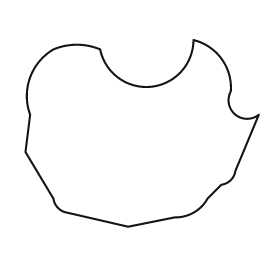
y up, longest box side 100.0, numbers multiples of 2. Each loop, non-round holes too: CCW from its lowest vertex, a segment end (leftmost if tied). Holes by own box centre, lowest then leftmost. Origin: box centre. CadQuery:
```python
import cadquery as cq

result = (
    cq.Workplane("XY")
    .moveTo(-6.0, -40.0)
    .lineTo(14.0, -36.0)
    .threePointArc((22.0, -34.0), (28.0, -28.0))
    .lineTo(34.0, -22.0)
    .threePointArc((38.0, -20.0), (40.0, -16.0))
    .lineTo(50.0, 8.0)
    .threePointArc((40.0, 8.0), (38.0, 18.0))
    .threePointArc((34.0, 32.0), (22.0, 40.0))
    .threePointArc((4.0, 20.0), (-18.0, 36.0))
    .threePointArc((-28.0, 38.0), (-38.0, 36.0))
    .threePointArc((-48.0, 24.0), (-48.0, 8.0))
    .lineTo(-50.0, -8.0)
    .lineTo(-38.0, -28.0)
    .threePointArc((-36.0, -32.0), (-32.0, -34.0))
    .close()
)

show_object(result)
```